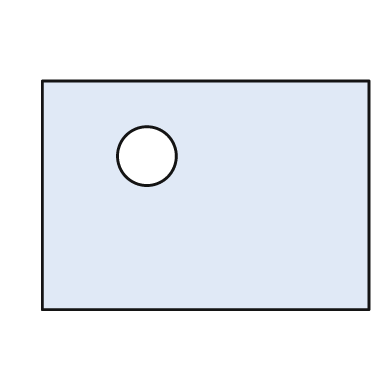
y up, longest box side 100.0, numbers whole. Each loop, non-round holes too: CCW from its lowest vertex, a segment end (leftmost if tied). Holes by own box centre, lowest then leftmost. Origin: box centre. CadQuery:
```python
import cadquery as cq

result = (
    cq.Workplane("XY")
    .moveTo(-50.0, -35.0)
    .lineTo(50.0, -35.0)
    .lineTo(50.0, 35.0)
    .lineTo(-50.0, 35.0)
    .close()
    .moveTo(-18.0, 12.0)
    .circle(9.0)
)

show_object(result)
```